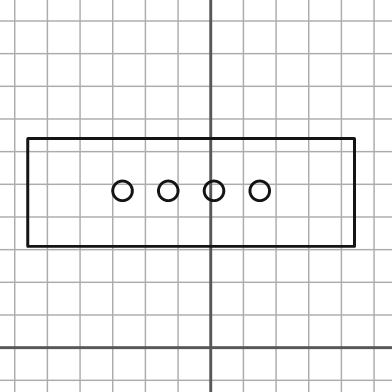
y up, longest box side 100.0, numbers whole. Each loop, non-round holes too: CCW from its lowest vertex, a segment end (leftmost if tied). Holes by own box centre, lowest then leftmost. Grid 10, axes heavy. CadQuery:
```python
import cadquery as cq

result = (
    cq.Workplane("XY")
    .moveTo(-56.0, 31.0)
    .lineTo(44.0, 31.0)
    .lineTo(44.0, 64.0)
    .lineTo(-56.0, 64.0)
    .close()
    .moveTo(-27.0, 48.0)
    .circle(3.0)
    .moveTo(-13.0, 48.0)
    .circle(3.0)
    .moveTo(1.0, 48.0)
    .circle(3.0)
    .moveTo(15.0, 48.0)
    .circle(3.0)
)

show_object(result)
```